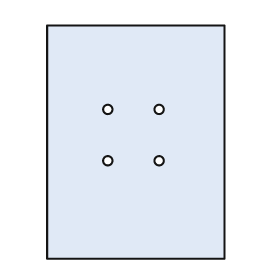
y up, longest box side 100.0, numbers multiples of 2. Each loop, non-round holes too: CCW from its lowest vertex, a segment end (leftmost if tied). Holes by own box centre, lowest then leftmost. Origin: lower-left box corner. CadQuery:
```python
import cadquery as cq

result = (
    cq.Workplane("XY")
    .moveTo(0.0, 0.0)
    .lineTo(76.0, 0.0)
    .lineTo(76.0, 100.0)
    .lineTo(0.0, 100.0)
    .close()
    .moveTo(26.0, 42.0)
    .circle(2.0)
    .moveTo(48.0, 42.0)
    .circle(2.0)
    .moveTo(26.0, 64.0)
    .circle(2.0)
    .moveTo(48.0, 64.0)
    .circle(2.0)
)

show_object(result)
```